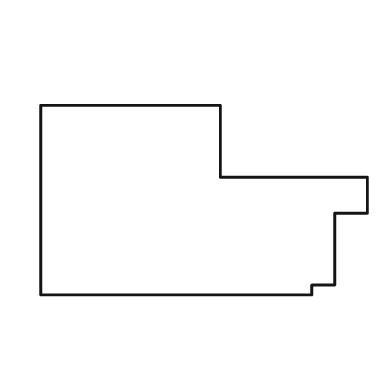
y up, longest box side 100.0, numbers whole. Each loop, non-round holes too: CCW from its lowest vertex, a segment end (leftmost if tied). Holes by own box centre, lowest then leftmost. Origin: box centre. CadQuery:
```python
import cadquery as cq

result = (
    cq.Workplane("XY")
    .moveTo(-50.0, -29.0)
    .lineTo(33.0, -29.0)
    .lineTo(33.0, -26.0)
    .lineTo(40.0, -26.0)
    .lineTo(40.0, -4.0)
    .lineTo(50.0, -4.0)
    .lineTo(50.0, 7.0)
    .lineTo(5.0, 7.0)
    .lineTo(5.0, 29.0)
    .lineTo(-50.0, 29.0)
    .close()
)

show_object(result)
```